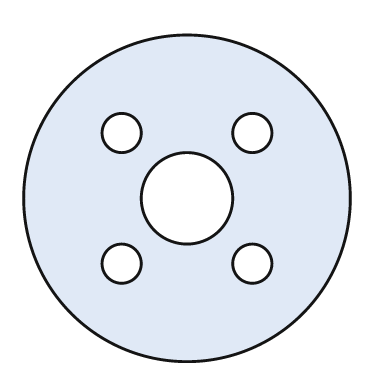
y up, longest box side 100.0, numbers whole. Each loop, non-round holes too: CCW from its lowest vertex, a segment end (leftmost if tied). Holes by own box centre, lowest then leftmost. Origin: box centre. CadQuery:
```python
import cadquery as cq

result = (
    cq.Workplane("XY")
    .moveTo(0.0, 0.0)
    .circle(50.0)
    .moveTo(-20.0, -20.0)
    .circle(6.0)
    .moveTo(20.0, -20.0)
    .circle(6.0)
    .moveTo(0.0, 0.0)
    .circle(14.0)
    .moveTo(-20.0, 20.0)
    .circle(6.0)
    .moveTo(20.0, 20.0)
    .circle(6.0)
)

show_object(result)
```